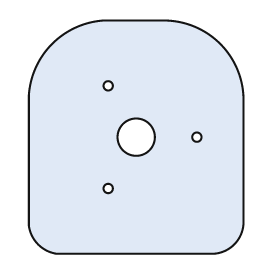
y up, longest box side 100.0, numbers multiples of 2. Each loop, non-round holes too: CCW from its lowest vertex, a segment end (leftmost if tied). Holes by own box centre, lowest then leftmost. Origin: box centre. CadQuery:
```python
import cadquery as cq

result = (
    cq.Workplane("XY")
    .moveTo(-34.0, -50.0)
    .lineTo(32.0, -50.0)
    .threePointArc((42.0, -46.0), (46.0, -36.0))
    .lineTo(46.0, 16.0)
    .threePointArc((36.0, 40.0), (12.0, 50.0))
    .lineTo(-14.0, 50.0)
    .threePointArc((-36.0, 40.0), (-46.0, 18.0))
    .lineTo(-46.0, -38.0)
    .threePointArc((-42.0, -46.0), (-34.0, -50.0))
    .close()
    .moveTo(-12.0, -22.0)
    .circle(2.0)
    .moveTo(0.0, 0.0)
    .circle(8.0)
    .moveTo(26.0, 0.0)
    .circle(2.0)
    .moveTo(-12.0, 22.0)
    .circle(2.0)
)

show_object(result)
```